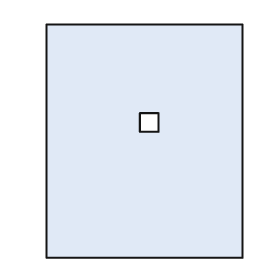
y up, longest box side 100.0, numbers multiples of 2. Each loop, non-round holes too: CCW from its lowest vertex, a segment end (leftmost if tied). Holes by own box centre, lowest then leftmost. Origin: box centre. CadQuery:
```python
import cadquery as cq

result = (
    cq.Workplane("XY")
    .moveTo(-42.0, -50.0)
    .lineTo(42.0, -50.0)
    .lineTo(42.0, 50.0)
    .lineTo(-42.0, 50.0)
    .close()
    .moveTo(-2.0, 4.0)
    .lineTo(6.0, 4.0)
    .lineTo(6.0, 12.0)
    .lineTo(-2.0, 12.0)
    .close()
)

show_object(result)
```